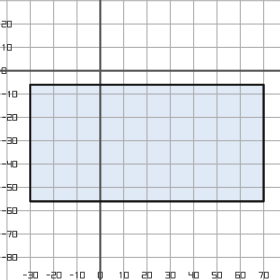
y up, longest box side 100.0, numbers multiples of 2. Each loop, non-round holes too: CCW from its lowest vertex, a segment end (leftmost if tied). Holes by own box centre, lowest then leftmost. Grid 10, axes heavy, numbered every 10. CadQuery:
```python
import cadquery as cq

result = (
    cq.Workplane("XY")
    .moveTo(-30.0, -56.0)
    .lineTo(70.0, -56.0)
    .lineTo(70.0, -6.0)
    .lineTo(-30.0, -6.0)
    .close()
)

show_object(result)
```